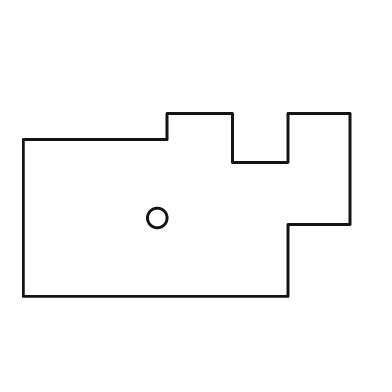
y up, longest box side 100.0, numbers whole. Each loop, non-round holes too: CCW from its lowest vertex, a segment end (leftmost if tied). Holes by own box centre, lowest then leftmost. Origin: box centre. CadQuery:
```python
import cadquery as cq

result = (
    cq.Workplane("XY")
    .moveTo(-50.0, -28.0)
    .lineTo(31.0, -28.0)
    .lineTo(31.0, -6.0)
    .lineTo(50.0, -6.0)
    .lineTo(50.0, 28.0)
    .lineTo(31.0, 28.0)
    .lineTo(31.0, 13.0)
    .lineTo(14.0, 13.0)
    .lineTo(14.0, 28.0)
    .lineTo(-6.0, 28.0)
    .lineTo(-6.0, 20.0)
    .lineTo(-50.0, 20.0)
    .close()
    .moveTo(-9.0, -4.0)
    .circle(3.0)
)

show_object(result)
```